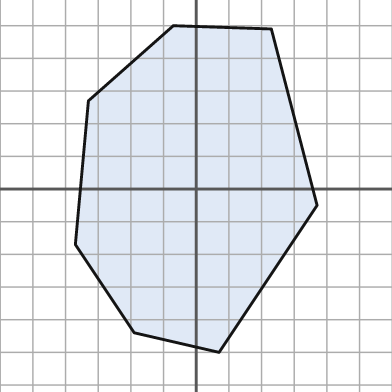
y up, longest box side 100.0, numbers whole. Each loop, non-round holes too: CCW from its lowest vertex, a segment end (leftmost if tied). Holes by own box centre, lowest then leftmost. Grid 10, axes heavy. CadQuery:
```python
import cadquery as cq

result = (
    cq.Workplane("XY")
    .moveTo(7.0, -50.0)
    .lineTo(37.0, -5.0)
    .lineTo(23.0, 49.0)
    .lineTo(-7.0, 50.0)
    .lineTo(-33.0, 27.0)
    .lineTo(-37.0, -17.0)
    .lineTo(-19.0, -44.0)
    .close()
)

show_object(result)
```